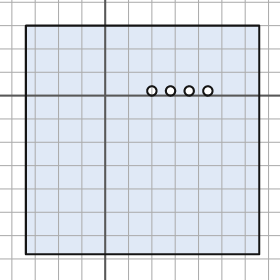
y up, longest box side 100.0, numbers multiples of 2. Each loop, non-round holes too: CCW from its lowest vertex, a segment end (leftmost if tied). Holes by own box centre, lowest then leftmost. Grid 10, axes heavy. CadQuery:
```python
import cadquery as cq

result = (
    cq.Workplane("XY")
    .moveTo(-34.0, -68.0)
    .lineTo(66.0, -68.0)
    .lineTo(66.0, 30.0)
    .lineTo(-34.0, 30.0)
    .close()
    .moveTo(20.0, 2.0)
    .circle(2.0)
    .moveTo(28.0, 2.0)
    .circle(2.0)
    .moveTo(36.0, 2.0)
    .circle(2.0)
    .moveTo(44.0, 2.0)
    .circle(2.0)
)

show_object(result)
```